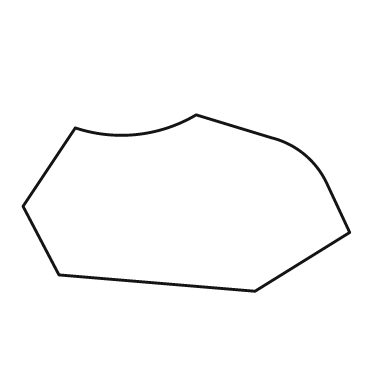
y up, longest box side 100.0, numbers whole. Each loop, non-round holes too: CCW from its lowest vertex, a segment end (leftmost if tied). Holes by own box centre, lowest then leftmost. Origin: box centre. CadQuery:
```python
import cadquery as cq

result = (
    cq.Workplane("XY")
    .moveTo(21.0, -27.0)
    .lineTo(50.0, -9.0)
    .lineTo(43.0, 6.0)
    .threePointArc((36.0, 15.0), (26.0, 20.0))
    .lineTo(3.0, 27.0)
    .threePointArc((-15.0, 21.0), (-34.0, 23.0))
    .lineTo(-50.0, -1.0)
    .lineTo(-39.0, -22.0)
    .close()
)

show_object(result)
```